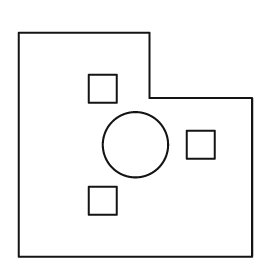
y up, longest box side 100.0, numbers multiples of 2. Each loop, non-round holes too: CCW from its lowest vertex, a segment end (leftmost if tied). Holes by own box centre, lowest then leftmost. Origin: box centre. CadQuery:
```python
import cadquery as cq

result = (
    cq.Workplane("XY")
    .moveTo(-50.0, -48.0)
    .lineTo(50.0, -48.0)
    .lineTo(50.0, 20.0)
    .lineTo(6.0, 20.0)
    .lineTo(6.0, 48.0)
    .lineTo(-50.0, 48.0)
    .close()
    .moveTo(-20.0, -30.0)
    .lineTo(-8.0, -30.0)
    .lineTo(-8.0, -18.0)
    .lineTo(-20.0, -18.0)
    .close()
    .moveTo(0.0, 0.0)
    .circle(14.0)
    .moveTo(22.0, -6.0)
    .lineTo(34.0, -6.0)
    .lineTo(34.0, 6.0)
    .lineTo(22.0, 6.0)
    .close()
    .moveTo(-20.0, 18.0)
    .lineTo(-8.0, 18.0)
    .lineTo(-8.0, 30.0)
    .lineTo(-20.0, 30.0)
    .close()
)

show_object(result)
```